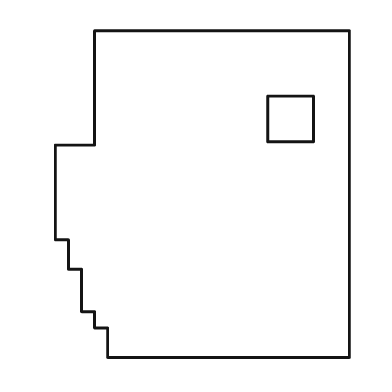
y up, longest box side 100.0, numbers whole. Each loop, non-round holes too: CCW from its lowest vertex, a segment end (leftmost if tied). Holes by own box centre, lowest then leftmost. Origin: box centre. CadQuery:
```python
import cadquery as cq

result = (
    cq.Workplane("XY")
    .moveTo(-29.0, -50.0)
    .lineTo(45.0, -50.0)
    .lineTo(45.0, 50.0)
    .lineTo(-33.0, 50.0)
    .lineTo(-33.0, 15.0)
    .lineTo(-45.0, 15.0)
    .lineTo(-45.0, -14.0)
    .lineTo(-41.0, -14.0)
    .lineTo(-41.0, -23.0)
    .lineTo(-37.0, -23.0)
    .lineTo(-37.0, -36.0)
    .lineTo(-33.0, -36.0)
    .lineTo(-33.0, -41.0)
    .lineTo(-29.0, -41.0)
    .close()
    .moveTo(20.0, 16.0)
    .lineTo(34.0, 16.0)
    .lineTo(34.0, 30.0)
    .lineTo(20.0, 30.0)
    .close()
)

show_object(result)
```